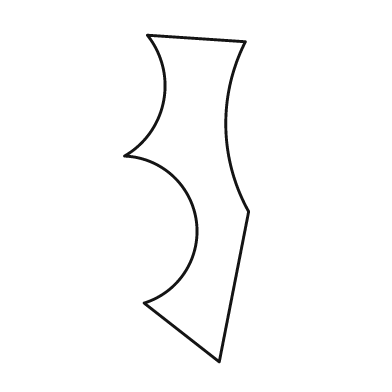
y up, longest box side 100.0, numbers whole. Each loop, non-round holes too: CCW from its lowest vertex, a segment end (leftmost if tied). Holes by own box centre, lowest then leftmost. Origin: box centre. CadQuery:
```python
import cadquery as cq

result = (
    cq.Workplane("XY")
    .moveTo(10.0, -50.0)
    .lineTo(19.0, -4.0)
    .threePointArc((12.0, 22.0), (18.0, 48.0))
    .lineTo(-12.0, 50.0)
    .threePointArc((-7.0, 30.0), (-19.0, 13.0))
    .threePointArc((3.0, -7.0), (-13.0, -32.0))
    .close()
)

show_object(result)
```